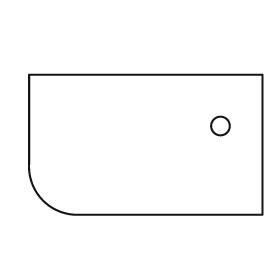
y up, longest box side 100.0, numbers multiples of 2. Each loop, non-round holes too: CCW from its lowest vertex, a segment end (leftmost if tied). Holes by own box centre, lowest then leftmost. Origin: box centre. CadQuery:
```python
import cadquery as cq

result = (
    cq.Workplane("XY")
    .moveTo(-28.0, -30.0)
    .lineTo(50.0, -30.0)
    .lineTo(50.0, 30.0)
    .lineTo(-50.0, 30.0)
    .lineTo(-50.0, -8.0)
    .threePointArc((-44.0, -24.0), (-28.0, -30.0))
    .close()
    .moveTo(32.0, 8.0)
    .circle(4.0)
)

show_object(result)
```